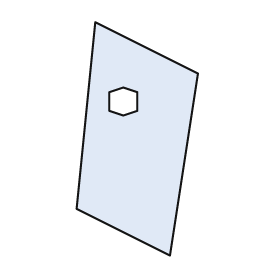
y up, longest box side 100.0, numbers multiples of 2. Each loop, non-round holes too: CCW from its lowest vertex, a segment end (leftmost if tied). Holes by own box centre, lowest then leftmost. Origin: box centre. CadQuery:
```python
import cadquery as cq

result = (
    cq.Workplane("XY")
    .moveTo(14.0, -50.0)
    .lineTo(26.0, 28.0)
    .lineTo(-18.0, 50.0)
    .lineTo(-26.0, -30.0)
    .close()
    .moveTo(-6.0, 10.0)
    .lineTo(0.0, 12.0)
    .lineTo(0.0, 20.0)
    .lineTo(-6.0, 22.0)
    .lineTo(-12.0, 20.0)
    .lineTo(-12.0, 12.0)
    .close()
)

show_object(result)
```